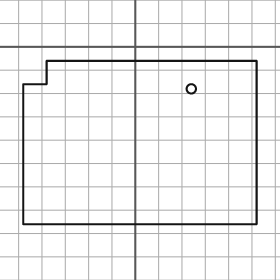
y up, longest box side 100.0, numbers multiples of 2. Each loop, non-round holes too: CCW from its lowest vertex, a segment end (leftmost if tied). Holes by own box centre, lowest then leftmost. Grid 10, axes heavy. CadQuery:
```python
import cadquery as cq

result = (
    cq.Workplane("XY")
    .moveTo(-48.0, -76.0)
    .lineTo(52.0, -76.0)
    .lineTo(52.0, -6.0)
    .lineTo(-38.0, -6.0)
    .lineTo(-38.0, -16.0)
    .lineTo(-48.0, -16.0)
    .close()
    .moveTo(24.0, -18.0)
    .circle(2.0)
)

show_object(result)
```